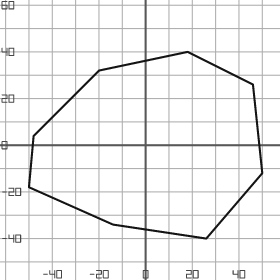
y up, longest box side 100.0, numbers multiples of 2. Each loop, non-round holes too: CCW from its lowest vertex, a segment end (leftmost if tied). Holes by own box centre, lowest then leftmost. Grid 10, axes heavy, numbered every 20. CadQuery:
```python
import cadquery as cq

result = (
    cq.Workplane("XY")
    .moveTo(26.0, -40.0)
    .lineTo(50.0, -12.0)
    .lineTo(46.0, 26.0)
    .lineTo(18.0, 40.0)
    .lineTo(-20.0, 32.0)
    .lineTo(-48.0, 4.0)
    .lineTo(-50.0, -18.0)
    .lineTo(-14.0, -34.0)
    .close()
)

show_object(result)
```